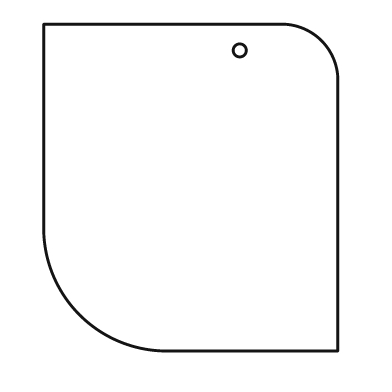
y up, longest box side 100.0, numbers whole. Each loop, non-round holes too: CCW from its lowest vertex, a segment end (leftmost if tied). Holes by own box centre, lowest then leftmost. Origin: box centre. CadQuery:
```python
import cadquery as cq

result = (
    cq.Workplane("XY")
    .moveTo(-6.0, -50.0)
    .lineTo(45.0, -50.0)
    .lineTo(45.0, 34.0)
    .threePointArc((40.0, 45.0), (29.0, 50.0))
    .lineTo(-45.0, 50.0)
    .lineTo(-45.0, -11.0)
    .threePointArc((-34.0, -39.0), (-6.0, -50.0))
    .close()
    .moveTo(15.0, 42.0)
    .circle(2.0)
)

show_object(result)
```